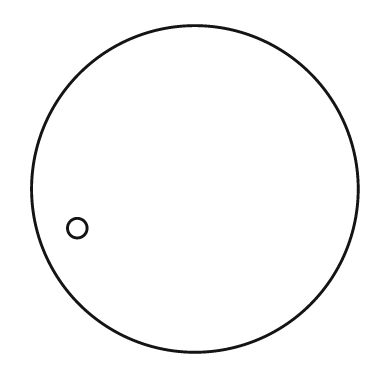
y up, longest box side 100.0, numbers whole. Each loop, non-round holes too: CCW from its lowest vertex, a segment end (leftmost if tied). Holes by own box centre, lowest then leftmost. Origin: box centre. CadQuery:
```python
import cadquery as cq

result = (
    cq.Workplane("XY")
    .moveTo(0.0, 0.0)
    .circle(50.0)
    .moveTo(-36.0, -12.0)
    .circle(3.0)
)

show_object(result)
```